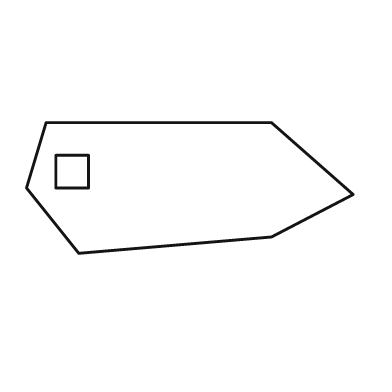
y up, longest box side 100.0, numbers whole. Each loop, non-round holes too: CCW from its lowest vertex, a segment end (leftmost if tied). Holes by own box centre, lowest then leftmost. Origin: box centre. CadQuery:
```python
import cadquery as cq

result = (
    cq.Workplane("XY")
    .moveTo(-34.0, -20.0)
    .lineTo(25.0, -15.0)
    .lineTo(50.0, -2.0)
    .lineTo(25.0, 20.0)
    .lineTo(-44.0, 20.0)
    .lineTo(-50.0, 0.0)
    .close()
    .moveTo(-41.0, 0.0)
    .lineTo(-31.0, 0.0)
    .lineTo(-31.0, 10.0)
    .lineTo(-41.0, 10.0)
    .close()
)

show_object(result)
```